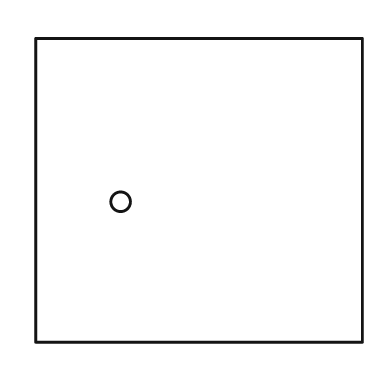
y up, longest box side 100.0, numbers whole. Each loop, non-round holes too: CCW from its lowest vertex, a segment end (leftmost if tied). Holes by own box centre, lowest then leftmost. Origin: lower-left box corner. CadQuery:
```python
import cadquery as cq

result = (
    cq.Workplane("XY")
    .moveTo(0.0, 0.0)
    .lineTo(100.0, 0.0)
    .lineTo(100.0, 93.0)
    .lineTo(0.0, 93.0)
    .close()
    .moveTo(26.0, 43.0)
    .circle(3.0)
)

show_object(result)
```